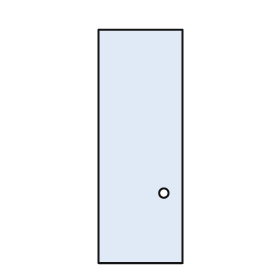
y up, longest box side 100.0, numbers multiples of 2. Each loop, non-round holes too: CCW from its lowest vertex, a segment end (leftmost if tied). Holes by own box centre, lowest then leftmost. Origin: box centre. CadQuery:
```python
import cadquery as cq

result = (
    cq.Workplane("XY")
    .moveTo(-18.0, -50.0)
    .lineTo(18.0, -50.0)
    .lineTo(18.0, 50.0)
    .lineTo(-18.0, 50.0)
    .close()
    .moveTo(10.0, -20.0)
    .circle(2.0)
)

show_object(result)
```